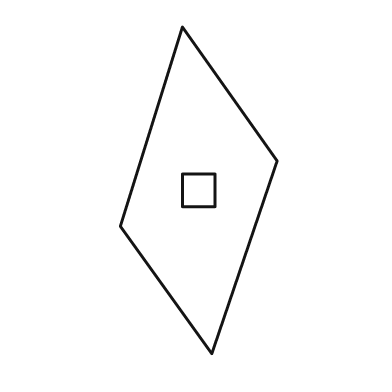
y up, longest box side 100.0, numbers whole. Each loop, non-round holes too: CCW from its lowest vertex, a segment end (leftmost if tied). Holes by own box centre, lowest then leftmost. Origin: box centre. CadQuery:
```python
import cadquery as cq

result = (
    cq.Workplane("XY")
    .moveTo(4.0, -50.0)
    .lineTo(24.0, 9.0)
    .lineTo(-5.0, 50.0)
    .lineTo(-24.0, -11.0)
    .close()
    .moveTo(-5.0, -5.0)
    .lineTo(5.0, -5.0)
    .lineTo(5.0, 5.0)
    .lineTo(-5.0, 5.0)
    .close()
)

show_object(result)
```